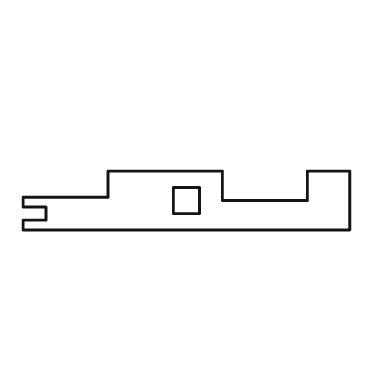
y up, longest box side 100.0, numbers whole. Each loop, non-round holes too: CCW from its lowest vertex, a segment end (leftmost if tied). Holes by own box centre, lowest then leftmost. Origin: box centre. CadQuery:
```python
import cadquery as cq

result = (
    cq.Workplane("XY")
    .moveTo(-50.0, -9.0)
    .lineTo(50.0, -9.0)
    .lineTo(50.0, 9.0)
    .lineTo(37.0, 9.0)
    .lineTo(37.0, 0.0)
    .lineTo(11.0, 0.0)
    .lineTo(11.0, 9.0)
    .lineTo(-24.0, 9.0)
    .lineTo(-24.0, 1.0)
    .lineTo(-50.0, 1.0)
    .lineTo(-50.0, -2.0)
    .lineTo(-43.0, -2.0)
    .lineTo(-43.0, -6.0)
    .lineTo(-50.0, -6.0)
    .close()
    .moveTo(-4.0, -4.0)
    .lineTo(4.0, -4.0)
    .lineTo(4.0, 4.0)
    .lineTo(-4.0, 4.0)
    .close()
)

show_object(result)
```